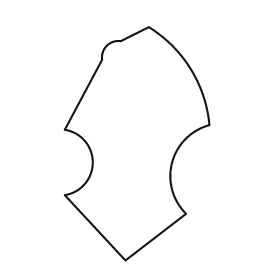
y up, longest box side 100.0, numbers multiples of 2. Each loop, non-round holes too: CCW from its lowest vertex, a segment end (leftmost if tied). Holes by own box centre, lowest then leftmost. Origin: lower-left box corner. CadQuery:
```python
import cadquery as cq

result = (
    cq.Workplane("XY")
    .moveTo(26.0, 0.0)
    .lineTo(52.0, 20.0)
    .threePointArc((46.0, 42.0), (62.0, 58.0))
    .threePointArc((54.0, 82.0), (36.0, 100.0))
    .lineTo(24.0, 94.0)
    .threePointArc((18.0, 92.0), (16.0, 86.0))
    .lineTo(0.0, 56.0)
    .threePointArc((12.0, 42.0), (0.0, 28.0))
    .close()
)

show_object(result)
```